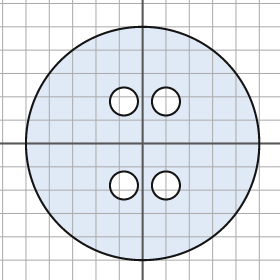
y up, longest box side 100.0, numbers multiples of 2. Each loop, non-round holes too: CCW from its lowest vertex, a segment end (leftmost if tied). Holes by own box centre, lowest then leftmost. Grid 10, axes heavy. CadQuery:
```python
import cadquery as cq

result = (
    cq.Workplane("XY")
    .moveTo(0.0, 0.0)
    .circle(50.0)
    .moveTo(-8.0, -18.0)
    .circle(6.0)
    .moveTo(10.0, -18.0)
    .circle(6.0)
    .moveTo(-8.0, 18.0)
    .circle(6.0)
    .moveTo(10.0, 18.0)
    .circle(6.0)
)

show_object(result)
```